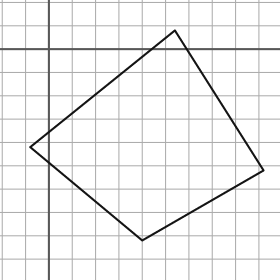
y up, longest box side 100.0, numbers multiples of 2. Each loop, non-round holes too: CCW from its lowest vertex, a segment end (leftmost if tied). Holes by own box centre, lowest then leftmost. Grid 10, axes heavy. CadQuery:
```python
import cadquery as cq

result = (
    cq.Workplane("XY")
    .moveTo(40.0, -82.0)
    .lineTo(92.0, -52.0)
    .lineTo(54.0, 8.0)
    .lineTo(-8.0, -42.0)
    .close()
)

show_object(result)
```